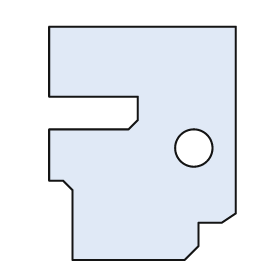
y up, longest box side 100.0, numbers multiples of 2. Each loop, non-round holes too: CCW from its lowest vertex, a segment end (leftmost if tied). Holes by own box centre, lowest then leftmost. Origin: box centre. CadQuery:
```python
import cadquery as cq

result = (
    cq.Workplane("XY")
    .moveTo(-30.0, -50.0)
    .lineTo(18.0, -50.0)
    .lineTo(24.0, -44.0)
    .lineTo(24.0, -34.0)
    .lineTo(34.0, -34.0)
    .lineTo(40.0, -30.0)
    .lineTo(40.0, 50.0)
    .lineTo(-40.0, 50.0)
    .lineTo(-40.0, 20.0)
    .lineTo(-2.0, 20.0)
    .lineTo(-2.0, 10.0)
    .lineTo(-6.0, 6.0)
    .lineTo(-40.0, 6.0)
    .lineTo(-40.0, -16.0)
    .lineTo(-34.0, -16.0)
    .lineTo(-30.0, -20.0)
    .close()
    .moveTo(22.0, -2.0)
    .circle(8.0)
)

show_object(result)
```